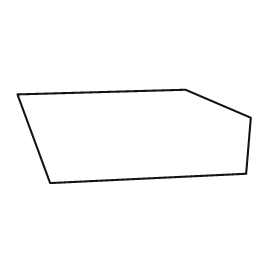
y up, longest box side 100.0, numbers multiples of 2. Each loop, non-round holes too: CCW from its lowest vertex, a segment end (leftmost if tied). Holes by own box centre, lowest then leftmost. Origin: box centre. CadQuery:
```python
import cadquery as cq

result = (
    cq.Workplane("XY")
    .moveTo(-36.0, -20.0)
    .lineTo(48.0, -16.0)
    .lineTo(50.0, 8.0)
    .lineTo(22.0, 20.0)
    .lineTo(-50.0, 18.0)
    .close()
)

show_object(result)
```